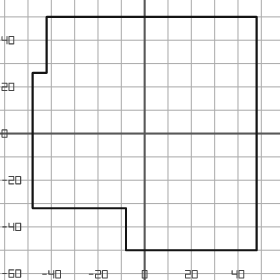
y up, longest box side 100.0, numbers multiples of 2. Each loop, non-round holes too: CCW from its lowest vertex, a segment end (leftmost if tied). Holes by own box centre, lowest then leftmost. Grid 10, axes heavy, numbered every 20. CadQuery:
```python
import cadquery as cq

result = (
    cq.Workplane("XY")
    .moveTo(-8.0, -50.0)
    .lineTo(48.0, -50.0)
    .lineTo(48.0, 50.0)
    .lineTo(-42.0, 50.0)
    .lineTo(-42.0, 26.0)
    .lineTo(-48.0, 26.0)
    .lineTo(-48.0, -32.0)
    .lineTo(-8.0, -32.0)
    .close()
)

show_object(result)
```